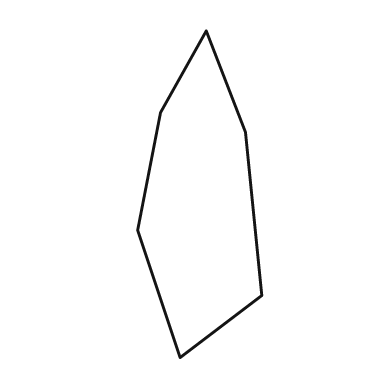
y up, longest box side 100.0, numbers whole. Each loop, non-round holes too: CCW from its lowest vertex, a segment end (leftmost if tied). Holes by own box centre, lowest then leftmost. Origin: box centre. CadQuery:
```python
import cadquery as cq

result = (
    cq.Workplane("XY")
    .moveTo(-6.0, -50.0)
    .lineTo(19.0, -31.0)
    .lineTo(14.0, 19.0)
    .lineTo(2.0, 50.0)
    .lineTo(-12.0, 25.0)
    .lineTo(-19.0, -11.0)
    .close()
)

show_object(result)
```